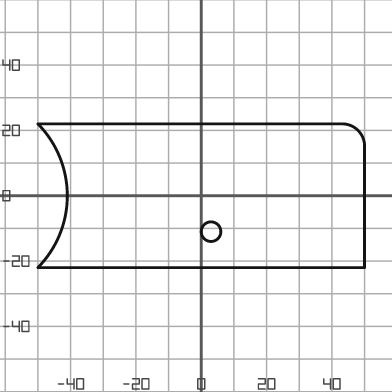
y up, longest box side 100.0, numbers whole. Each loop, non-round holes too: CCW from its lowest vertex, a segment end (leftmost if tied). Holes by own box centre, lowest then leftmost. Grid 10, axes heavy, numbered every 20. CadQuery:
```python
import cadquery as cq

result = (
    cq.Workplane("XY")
    .moveTo(-50.0, -22.0)
    .lineTo(50.0, -22.0)
    .lineTo(50.0, 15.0)
    .threePointArc((48.0, 20.0), (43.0, 22.0))
    .lineTo(-50.0, 22.0)
    .threePointArc((-41.0, 0.0), (-50.0, -22.0))
    .close()
    .moveTo(3.0, -11.0)
    .circle(3.0)
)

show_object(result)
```